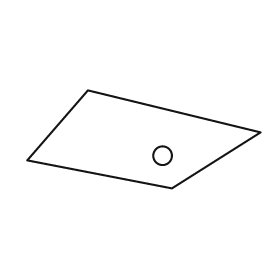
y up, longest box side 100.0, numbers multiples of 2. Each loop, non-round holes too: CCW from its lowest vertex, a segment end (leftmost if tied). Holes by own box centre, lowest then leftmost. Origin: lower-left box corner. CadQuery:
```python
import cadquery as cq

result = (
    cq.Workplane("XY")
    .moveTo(62.0, 0.0)
    .lineTo(100.0, 24.0)
    .lineTo(26.0, 42.0)
    .lineTo(0.0, 12.0)
    .close()
    .moveTo(58.0, 14.0)
    .circle(4.0)
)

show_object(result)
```